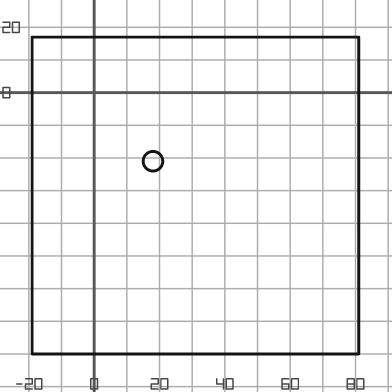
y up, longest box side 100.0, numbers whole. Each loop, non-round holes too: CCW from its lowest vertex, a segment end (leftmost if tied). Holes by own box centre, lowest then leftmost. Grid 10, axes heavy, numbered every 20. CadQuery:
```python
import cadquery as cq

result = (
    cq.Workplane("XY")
    .moveTo(-19.0, -80.0)
    .lineTo(81.0, -80.0)
    .lineTo(81.0, 17.0)
    .lineTo(-19.0, 17.0)
    .close()
    .moveTo(18.0, -21.0)
    .circle(3.0)
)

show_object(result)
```